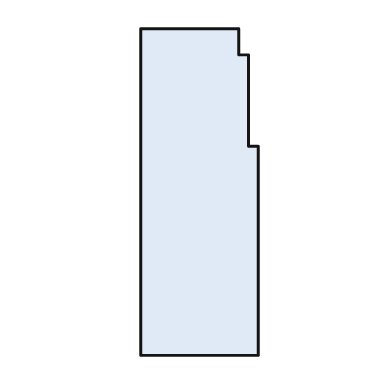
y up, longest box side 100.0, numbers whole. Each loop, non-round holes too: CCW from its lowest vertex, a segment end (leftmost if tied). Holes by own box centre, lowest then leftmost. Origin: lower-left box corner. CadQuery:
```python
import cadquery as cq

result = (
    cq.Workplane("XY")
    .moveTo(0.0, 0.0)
    .lineTo(36.0, 0.0)
    .lineTo(36.0, 64.0)
    .lineTo(33.0, 64.0)
    .lineTo(33.0, 92.0)
    .lineTo(30.0, 92.0)
    .lineTo(30.0, 100.0)
    .lineTo(0.0, 100.0)
    .close()
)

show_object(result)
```